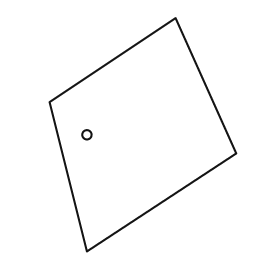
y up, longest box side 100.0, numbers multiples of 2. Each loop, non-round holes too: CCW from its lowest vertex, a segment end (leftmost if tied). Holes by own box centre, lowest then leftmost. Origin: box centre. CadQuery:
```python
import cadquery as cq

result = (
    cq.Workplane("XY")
    .moveTo(-24.0, -50.0)
    .lineTo(40.0, -8.0)
    .lineTo(14.0, 50.0)
    .lineTo(-40.0, 14.0)
    .close()
    .moveTo(-24.0, 0.0)
    .circle(2.0)
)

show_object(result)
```